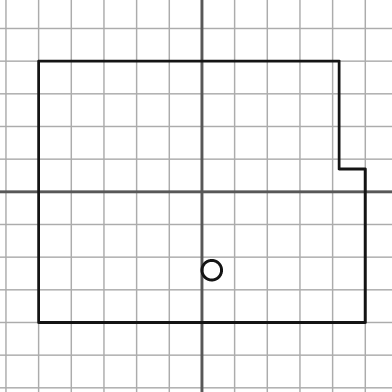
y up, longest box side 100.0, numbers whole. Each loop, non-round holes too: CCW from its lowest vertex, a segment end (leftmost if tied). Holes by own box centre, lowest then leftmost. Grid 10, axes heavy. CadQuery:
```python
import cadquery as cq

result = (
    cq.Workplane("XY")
    .moveTo(-50.0, -40.0)
    .lineTo(50.0, -40.0)
    .lineTo(50.0, 7.0)
    .lineTo(42.0, 7.0)
    .lineTo(42.0, 40.0)
    .lineTo(-50.0, 40.0)
    .close()
    .moveTo(3.0, -24.0)
    .circle(3.0)
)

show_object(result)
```